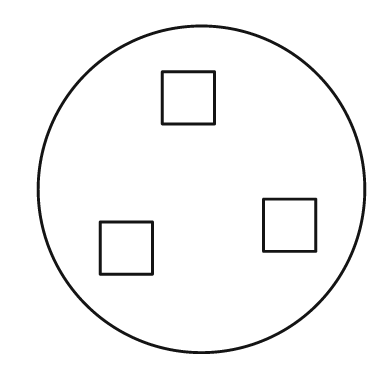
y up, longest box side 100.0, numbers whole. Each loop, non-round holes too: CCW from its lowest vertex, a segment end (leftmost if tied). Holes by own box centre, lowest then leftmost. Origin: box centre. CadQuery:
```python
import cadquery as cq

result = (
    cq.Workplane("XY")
    .moveTo(0.0, 0.0)
    .circle(50.0)
    .moveTo(-31.0, -26.0)
    .lineTo(-15.0, -26.0)
    .lineTo(-15.0, -10.0)
    .lineTo(-31.0, -10.0)
    .close()
    .moveTo(19.0, -19.0)
    .lineTo(35.0, -19.0)
    .lineTo(35.0, -3.0)
    .lineTo(19.0, -3.0)
    .close()
    .moveTo(-12.0, 20.0)
    .lineTo(4.0, 20.0)
    .lineTo(4.0, 36.0)
    .lineTo(-12.0, 36.0)
    .close()
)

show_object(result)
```